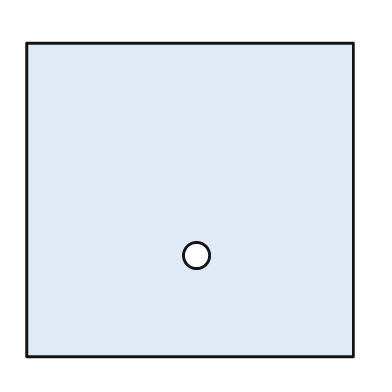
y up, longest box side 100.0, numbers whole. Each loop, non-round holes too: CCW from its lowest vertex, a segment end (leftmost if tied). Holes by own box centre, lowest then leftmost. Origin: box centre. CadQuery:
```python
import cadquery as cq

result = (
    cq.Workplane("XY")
    .moveTo(-50.0, -48.0)
    .lineTo(50.0, -48.0)
    .lineTo(50.0, 48.0)
    .lineTo(-50.0, 48.0)
    .close()
    .moveTo(2.0, -17.0)
    .circle(4.0)
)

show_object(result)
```